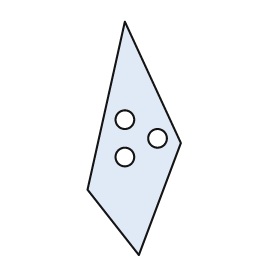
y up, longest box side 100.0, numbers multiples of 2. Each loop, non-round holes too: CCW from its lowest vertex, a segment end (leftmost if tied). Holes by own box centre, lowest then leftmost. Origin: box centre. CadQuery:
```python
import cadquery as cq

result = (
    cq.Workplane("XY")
    .moveTo(2.0, -50.0)
    .lineTo(20.0, -2.0)
    .lineTo(-4.0, 50.0)
    .lineTo(-20.0, -22.0)
    .close()
    .moveTo(-4.0, -8.0)
    .circle(4.0)
    .moveTo(10.0, 0.0)
    .circle(4.0)
    .moveTo(-4.0, 8.0)
    .circle(4.0)
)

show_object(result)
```